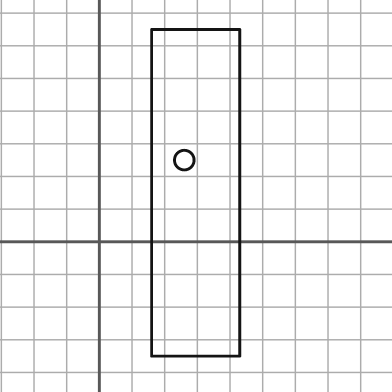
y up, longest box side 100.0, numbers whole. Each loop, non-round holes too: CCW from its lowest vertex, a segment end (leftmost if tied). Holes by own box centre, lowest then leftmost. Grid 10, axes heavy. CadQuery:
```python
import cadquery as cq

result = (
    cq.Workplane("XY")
    .moveTo(16.0, -35.0)
    .lineTo(43.0, -35.0)
    .lineTo(43.0, 65.0)
    .lineTo(16.0, 65.0)
    .close()
    .moveTo(26.0, 25.0)
    .circle(3.0)
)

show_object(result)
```